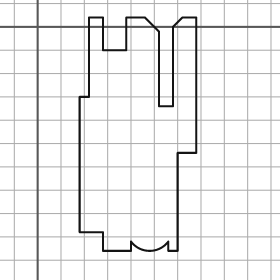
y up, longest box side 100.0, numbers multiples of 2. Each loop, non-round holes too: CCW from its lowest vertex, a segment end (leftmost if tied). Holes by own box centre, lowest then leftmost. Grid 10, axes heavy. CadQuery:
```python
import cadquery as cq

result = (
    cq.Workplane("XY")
    .moveTo(28.0, -96.0)
    .lineTo(40.0, -96.0)
    .lineTo(40.0, -92.0)
    .threePointArc((48.0, -96.0), (56.0, -92.0))
    .lineTo(56.0, -96.0)
    .lineTo(60.0, -96.0)
    .lineTo(60.0, -54.0)
    .lineTo(68.0, -54.0)
    .lineTo(68.0, 4.0)
    .lineTo(62.0, 4.0)
    .lineTo(58.0, 0.0)
    .lineTo(58.0, -34.0)
    .lineTo(52.0, -34.0)
    .lineTo(52.0, -2.0)
    .lineTo(46.0, 4.0)
    .lineTo(38.0, 4.0)
    .lineTo(38.0, -10.0)
    .lineTo(28.0, -10.0)
    .lineTo(28.0, 4.0)
    .lineTo(22.0, 4.0)
    .lineTo(22.0, -30.0)
    .lineTo(18.0, -30.0)
    .lineTo(18.0, -88.0)
    .lineTo(28.0, -88.0)
    .close()
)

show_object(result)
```